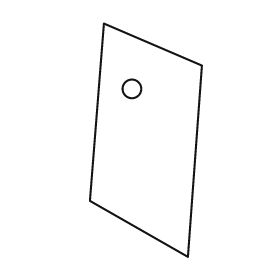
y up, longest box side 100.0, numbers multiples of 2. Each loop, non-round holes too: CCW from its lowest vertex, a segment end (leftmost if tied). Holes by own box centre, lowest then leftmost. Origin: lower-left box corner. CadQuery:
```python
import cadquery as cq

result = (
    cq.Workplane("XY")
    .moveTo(42.0, 0.0)
    .lineTo(48.0, 82.0)
    .lineTo(6.0, 100.0)
    .lineTo(0.0, 24.0)
    .close()
    .moveTo(18.0, 72.0)
    .circle(4.0)
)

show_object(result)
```